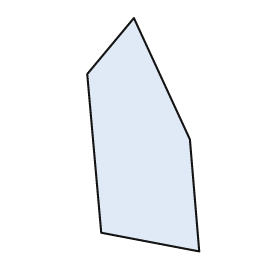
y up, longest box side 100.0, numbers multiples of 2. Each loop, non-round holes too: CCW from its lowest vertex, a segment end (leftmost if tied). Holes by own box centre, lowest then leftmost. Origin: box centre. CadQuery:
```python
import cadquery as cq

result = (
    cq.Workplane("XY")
    .moveTo(24.0, -50.0)
    .lineTo(20.0, -2.0)
    .lineTo(-4.0, 50.0)
    .lineTo(-24.0, 26.0)
    .lineTo(-18.0, -42.0)
    .close()
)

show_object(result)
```